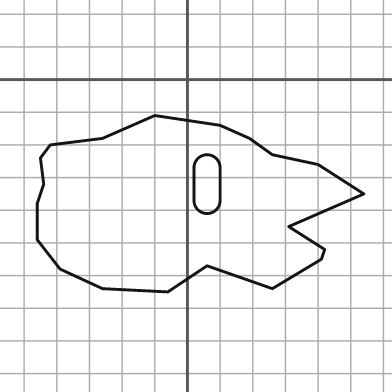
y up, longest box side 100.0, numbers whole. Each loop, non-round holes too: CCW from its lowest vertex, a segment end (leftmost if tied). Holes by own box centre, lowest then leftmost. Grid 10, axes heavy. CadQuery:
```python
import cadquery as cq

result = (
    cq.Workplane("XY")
    .moveTo(-6.0, -65.0)
    .lineTo(6.0, -57.0)
    .lineTo(26.0, -64.0)
    .lineTo(41.0, -55.0)
    .lineTo(42.0, -52.0)
    .lineTo(31.0, -45.0)
    .lineTo(54.0, -35.0)
    .lineTo(40.0, -26.0)
    .lineTo(26.0, -23.0)
    .lineTo(19.0, -18.0)
    .lineTo(10.0, -14.0)
    .lineTo(-10.0, -11.0)
    .lineTo(-26.0, -18.0)
    .lineTo(-42.0, -20.0)
    .lineTo(-45.0, -24.0)
    .lineTo(-44.0, -32.0)
    .lineTo(-46.0, -38.0)
    .lineTo(-46.0, -49.0)
    .lineTo(-39.0, -58.0)
    .lineTo(-26.0, -64.0)
    .close()
    .moveTo(2.0, -37.0)
    .threePointArc((6.0, -41.0), (10.0, -37.0))
    .lineTo(10.0, -27.0)
    .threePointArc((6.0, -23.0), (2.0, -27.0))
    .close()
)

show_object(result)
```